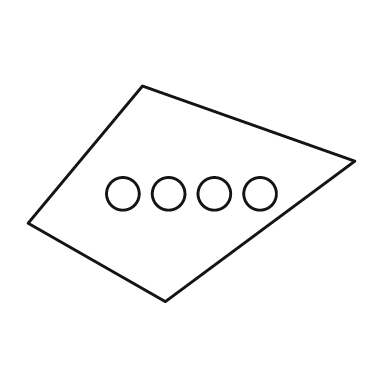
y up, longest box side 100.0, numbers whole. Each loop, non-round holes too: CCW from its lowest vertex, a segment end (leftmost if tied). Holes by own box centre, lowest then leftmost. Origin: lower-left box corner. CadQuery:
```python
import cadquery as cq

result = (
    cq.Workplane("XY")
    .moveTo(42.0, 0.0)
    .lineTo(100.0, 43.0)
    .lineTo(35.0, 66.0)
    .lineTo(0.0, 24.0)
    .close()
    .moveTo(29.0, 33.0)
    .circle(5.0)
    .moveTo(43.0, 33.0)
    .circle(5.0)
    .moveTo(57.0, 33.0)
    .circle(5.0)
    .moveTo(71.0, 33.0)
    .circle(5.0)
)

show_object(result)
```